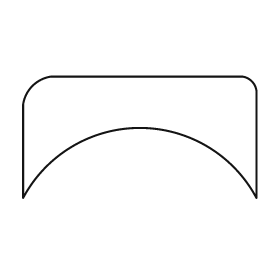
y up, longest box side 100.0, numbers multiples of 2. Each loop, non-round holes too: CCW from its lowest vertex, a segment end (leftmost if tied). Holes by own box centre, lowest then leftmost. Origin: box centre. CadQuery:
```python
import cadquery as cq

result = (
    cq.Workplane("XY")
    .moveTo(-50.0, -26.0)
    .threePointArc((0.0, 4.0), (50.0, -26.0))
    .lineTo(50.0, 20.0)
    .threePointArc((48.0, 24.0), (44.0, 26.0))
    .lineTo(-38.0, 26.0)
    .threePointArc((-46.0, 22.0), (-50.0, 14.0))
    .close()
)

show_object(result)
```